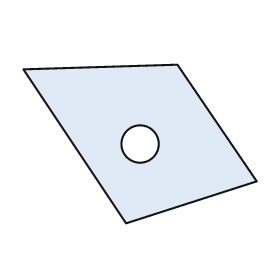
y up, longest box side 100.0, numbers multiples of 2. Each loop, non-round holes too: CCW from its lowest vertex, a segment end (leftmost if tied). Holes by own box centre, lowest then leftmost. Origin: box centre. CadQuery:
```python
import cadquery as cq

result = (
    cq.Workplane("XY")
    .moveTo(-6.0, -34.0)
    .lineTo(50.0, -16.0)
    .lineTo(16.0, 34.0)
    .lineTo(-50.0, 32.0)
    .close()
    .moveTo(0.0, 0.0)
    .circle(8.0)
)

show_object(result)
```